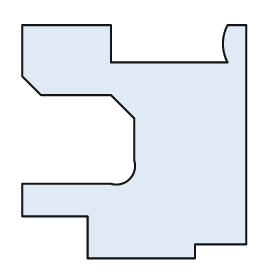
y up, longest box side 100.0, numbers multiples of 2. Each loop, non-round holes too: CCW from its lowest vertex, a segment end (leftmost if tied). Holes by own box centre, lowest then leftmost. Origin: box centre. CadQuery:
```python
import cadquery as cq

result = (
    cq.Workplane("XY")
    .moveTo(-20.0, -50.0)
    .lineTo(26.0, -50.0)
    .lineTo(26.0, -44.0)
    .lineTo(48.0, -44.0)
    .lineTo(48.0, 50.0)
    .lineTo(40.0, 50.0)
    .threePointArc((38.0, 42.0), (40.0, 34.0))
    .lineTo(-10.0, 34.0)
    .lineTo(-10.0, 50.0)
    .lineTo(-48.0, 50.0)
    .lineTo(-48.0, 28.0)
    .lineTo(-40.0, 20.0)
    .lineTo(-10.0, 20.0)
    .lineTo(0.0, 10.0)
    .lineTo(0.0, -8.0)
    .threePointArc((-2.0, -16.0), (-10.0, -18.0))
    .lineTo(-48.0, -18.0)
    .lineTo(-48.0, -32.0)
    .lineTo(-20.0, -32.0)
    .close()
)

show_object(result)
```